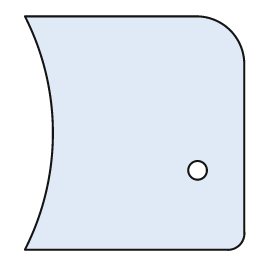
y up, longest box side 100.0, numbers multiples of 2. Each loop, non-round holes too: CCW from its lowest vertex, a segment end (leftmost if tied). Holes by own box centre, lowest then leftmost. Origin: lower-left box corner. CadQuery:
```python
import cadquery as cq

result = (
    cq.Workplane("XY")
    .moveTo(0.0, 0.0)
    .lineTo(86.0, 0.0)
    .threePointArc((92.0, 2.0), (94.0, 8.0))
    .lineTo(94.0, 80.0)
    .threePointArc((88.0, 94.0), (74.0, 100.0))
    .lineTo(0.0, 100.0)
    .threePointArc((12.0, 50.0), (0.0, 0.0))
    .close()
    .moveTo(74.0, 34.0)
    .circle(4.0)
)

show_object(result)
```